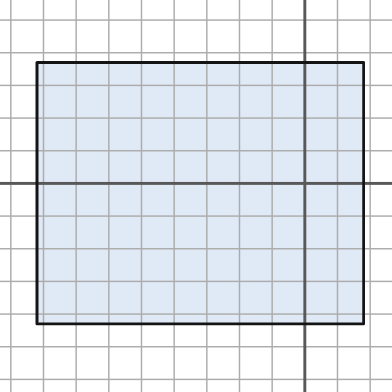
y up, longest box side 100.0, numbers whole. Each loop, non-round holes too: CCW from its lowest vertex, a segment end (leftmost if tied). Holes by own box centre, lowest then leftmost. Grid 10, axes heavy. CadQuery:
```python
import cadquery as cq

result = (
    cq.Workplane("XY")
    .moveTo(-82.0, -43.0)
    .lineTo(18.0, -43.0)
    .lineTo(18.0, 37.0)
    .lineTo(-82.0, 37.0)
    .close()
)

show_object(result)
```